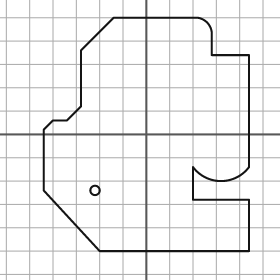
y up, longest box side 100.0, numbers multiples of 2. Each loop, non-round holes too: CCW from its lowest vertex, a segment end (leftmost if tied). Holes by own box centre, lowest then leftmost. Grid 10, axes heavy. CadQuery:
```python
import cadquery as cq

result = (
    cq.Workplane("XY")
    .moveTo(-20.0, -50.0)
    .lineTo(44.0, -50.0)
    .lineTo(44.0, -28.0)
    .lineTo(20.0, -28.0)
    .lineTo(20.0, -14.0)
    .threePointArc((32.0, -20.0), (44.0, -14.0))
    .lineTo(44.0, 34.0)
    .lineTo(28.0, 34.0)
    .lineTo(28.0, 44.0)
    .threePointArc((26.0, 48.0), (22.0, 50.0))
    .lineTo(-14.0, 50.0)
    .lineTo(-28.0, 36.0)
    .lineTo(-28.0, 12.0)
    .lineTo(-34.0, 6.0)
    .lineTo(-40.0, 6.0)
    .lineTo(-44.0, 2.0)
    .lineTo(-44.0, -24.0)
    .close()
    .moveTo(-22.0, -24.0)
    .circle(2.0)
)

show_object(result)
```